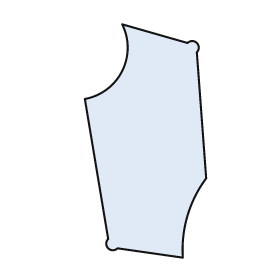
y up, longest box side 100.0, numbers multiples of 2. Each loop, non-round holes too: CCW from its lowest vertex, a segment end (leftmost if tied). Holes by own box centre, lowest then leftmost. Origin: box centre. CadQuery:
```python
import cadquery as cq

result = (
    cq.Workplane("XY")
    .moveTo(16.0, -50.0)
    .threePointArc((18.0, -32.0), (26.0, -16.0))
    .lineTo(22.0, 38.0)
    .threePointArc((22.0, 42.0), (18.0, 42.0))
    .lineTo(-10.0, 50.0)
    .threePointArc((-10.0, 30.0), (-26.0, 18.0))
    .lineTo(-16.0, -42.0)
    .threePointArc((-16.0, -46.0), (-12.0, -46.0))
    .close()
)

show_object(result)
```